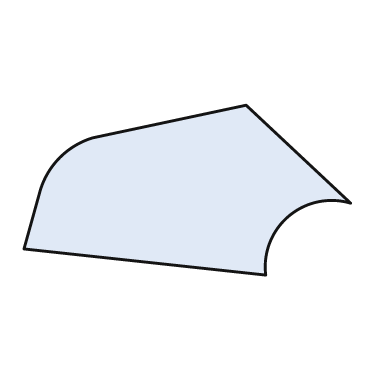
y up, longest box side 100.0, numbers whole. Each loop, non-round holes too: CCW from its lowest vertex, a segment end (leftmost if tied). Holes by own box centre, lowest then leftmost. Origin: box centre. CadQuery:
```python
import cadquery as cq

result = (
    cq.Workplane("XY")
    .moveTo(24.0, -26.0)
    .threePointArc((31.0, -8.0), (50.0, -4.0))
    .lineTo(18.0, 26.0)
    .lineTo(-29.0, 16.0)
    .threePointArc((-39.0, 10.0), (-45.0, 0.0))
    .lineTo(-50.0, -18.0)
    .close()
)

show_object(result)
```